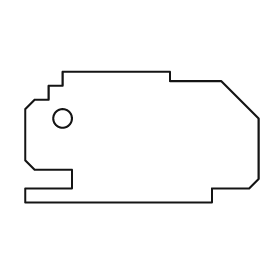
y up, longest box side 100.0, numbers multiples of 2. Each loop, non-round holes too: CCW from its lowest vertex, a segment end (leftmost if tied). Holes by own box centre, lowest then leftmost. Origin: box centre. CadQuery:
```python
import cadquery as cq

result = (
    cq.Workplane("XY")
    .moveTo(-50.0, -28.0)
    .lineTo(30.0, -28.0)
    .lineTo(30.0, -22.0)
    .lineTo(46.0, -22.0)
    .lineTo(50.0, -18.0)
    .lineTo(50.0, 8.0)
    .lineTo(34.0, 24.0)
    .lineTo(12.0, 24.0)
    .lineTo(12.0, 28.0)
    .lineTo(-34.0, 28.0)
    .lineTo(-34.0, 22.0)
    .lineTo(-40.0, 22.0)
    .lineTo(-40.0, 16.0)
    .lineTo(-46.0, 16.0)
    .lineTo(-50.0, 12.0)
    .lineTo(-50.0, -10.0)
    .lineTo(-46.0, -14.0)
    .lineTo(-30.0, -14.0)
    .lineTo(-30.0, -22.0)
    .lineTo(-50.0, -22.0)
    .close()
    .moveTo(-34.0, 8.0)
    .circle(4.0)
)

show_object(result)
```